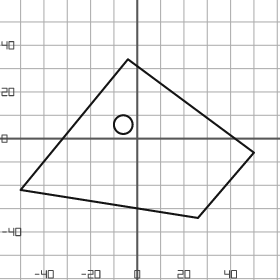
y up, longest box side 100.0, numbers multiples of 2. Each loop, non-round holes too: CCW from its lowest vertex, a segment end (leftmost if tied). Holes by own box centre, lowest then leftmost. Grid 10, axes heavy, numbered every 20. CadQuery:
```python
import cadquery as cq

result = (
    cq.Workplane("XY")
    .moveTo(26.0, -34.0)
    .lineTo(50.0, -6.0)
    .lineTo(-4.0, 34.0)
    .lineTo(-50.0, -22.0)
    .close()
    .moveTo(-6.0, 6.0)
    .circle(4.0)
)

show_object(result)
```